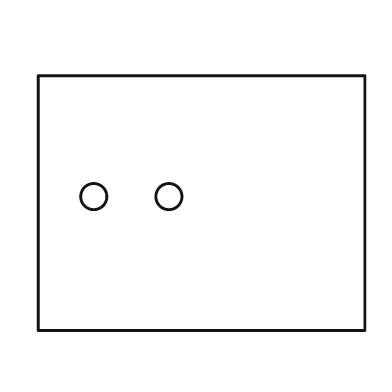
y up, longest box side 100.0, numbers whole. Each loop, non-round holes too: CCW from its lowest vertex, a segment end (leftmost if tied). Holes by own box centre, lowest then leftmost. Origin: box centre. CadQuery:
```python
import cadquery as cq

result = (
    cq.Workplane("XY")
    .moveTo(-50.0, -39.0)
    .lineTo(50.0, -39.0)
    .lineTo(50.0, 39.0)
    .lineTo(-50.0, 39.0)
    .close()
    .moveTo(-33.0, 2.0)
    .circle(4.0)
    .moveTo(-10.0, 2.0)
    .circle(4.0)
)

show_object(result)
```